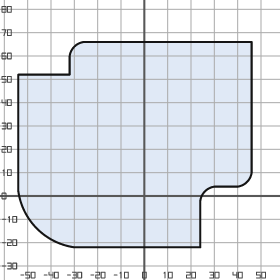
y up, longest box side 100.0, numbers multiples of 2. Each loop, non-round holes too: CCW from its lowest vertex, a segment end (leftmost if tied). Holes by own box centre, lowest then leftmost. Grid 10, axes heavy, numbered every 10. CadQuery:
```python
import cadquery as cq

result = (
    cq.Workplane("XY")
    .moveTo(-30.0, -22.0)
    .lineTo(24.0, -22.0)
    .lineTo(24.0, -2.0)
    .threePointArc((26.0, 2.0), (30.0, 4.0))
    .lineTo(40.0, 4.0)
    .threePointArc((44.0, 6.0), (46.0, 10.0))
    .lineTo(46.0, 66.0)
    .lineTo(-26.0, 66.0)
    .threePointArc((-30.0, 64.0), (-32.0, 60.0))
    .lineTo(-32.0, 52.0)
    .lineTo(-54.0, 52.0)
    .lineTo(-54.0, 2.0)
    .threePointArc((-46.0, -14.0), (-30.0, -22.0))
    .close()
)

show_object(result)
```